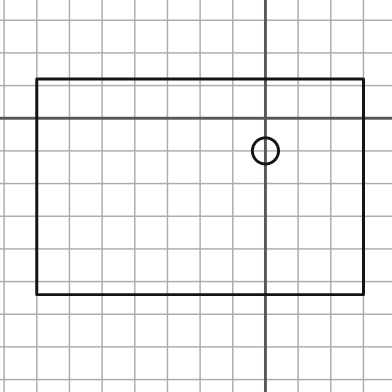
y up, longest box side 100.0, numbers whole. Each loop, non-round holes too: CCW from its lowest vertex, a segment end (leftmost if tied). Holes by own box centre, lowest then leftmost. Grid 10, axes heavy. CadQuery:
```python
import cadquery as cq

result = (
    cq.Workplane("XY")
    .moveTo(-70.0, -54.0)
    .lineTo(30.0, -54.0)
    .lineTo(30.0, 12.0)
    .lineTo(-70.0, 12.0)
    .close()
    .moveTo(0.0, -10.0)
    .circle(4.0)
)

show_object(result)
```